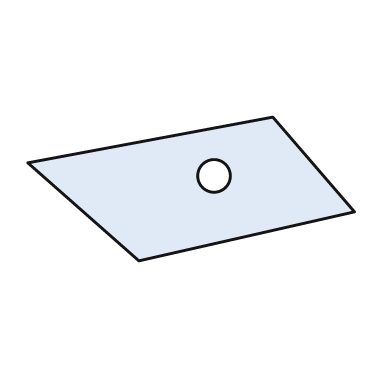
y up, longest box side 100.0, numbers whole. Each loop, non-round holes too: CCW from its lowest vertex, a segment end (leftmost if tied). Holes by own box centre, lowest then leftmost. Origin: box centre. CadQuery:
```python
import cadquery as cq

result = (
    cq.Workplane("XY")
    .moveTo(-16.0, -22.0)
    .lineTo(50.0, -7.0)
    .lineTo(25.0, 22.0)
    .lineTo(-50.0, 8.0)
    .close()
    .moveTo(7.0, 4.0)
    .circle(5.0)
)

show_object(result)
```